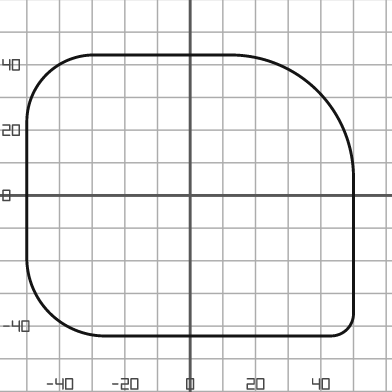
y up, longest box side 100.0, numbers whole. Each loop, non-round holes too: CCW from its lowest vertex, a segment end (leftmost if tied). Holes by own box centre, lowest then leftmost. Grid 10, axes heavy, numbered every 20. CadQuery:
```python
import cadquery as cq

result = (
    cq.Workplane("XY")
    .moveTo(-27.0, -43.0)
    .lineTo(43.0, -43.0)
    .threePointArc((48.0, -41.0), (50.0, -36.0))
    .lineTo(50.0, 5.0)
    .threePointArc((39.0, 32.0), (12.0, 43.0))
    .lineTo(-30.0, 43.0)
    .threePointArc((-44.0, 37.0), (-50.0, 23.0))
    .lineTo(-50.0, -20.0)
    .threePointArc((-43.0, -36.0), (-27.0, -43.0))
    .close()
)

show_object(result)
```